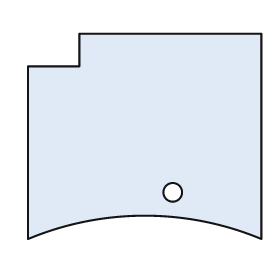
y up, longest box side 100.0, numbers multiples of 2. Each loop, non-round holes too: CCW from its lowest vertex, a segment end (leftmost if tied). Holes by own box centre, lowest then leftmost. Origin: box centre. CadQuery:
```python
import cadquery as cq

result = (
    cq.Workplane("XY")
    .moveTo(-50.0, -44.0)
    .threePointArc((0.0, -34.0), (50.0, -44.0))
    .lineTo(50.0, 44.0)
    .lineTo(-28.0, 44.0)
    .lineTo(-28.0, 30.0)
    .lineTo(-50.0, 30.0)
    .close()
    .moveTo(12.0, -24.0)
    .circle(4.0)
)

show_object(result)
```